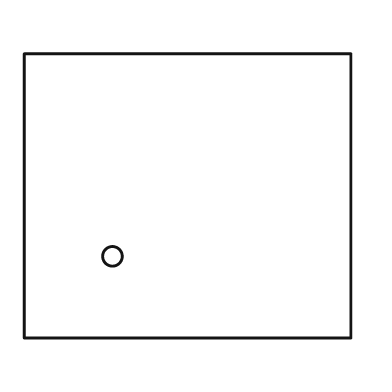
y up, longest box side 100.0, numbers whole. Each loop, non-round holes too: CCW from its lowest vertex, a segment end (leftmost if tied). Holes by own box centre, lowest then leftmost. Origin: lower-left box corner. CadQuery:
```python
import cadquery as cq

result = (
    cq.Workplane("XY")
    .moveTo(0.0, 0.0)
    .lineTo(100.0, 0.0)
    .lineTo(100.0, 87.0)
    .lineTo(0.0, 87.0)
    .close()
    .moveTo(27.0, 25.0)
    .circle(3.0)
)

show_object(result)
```